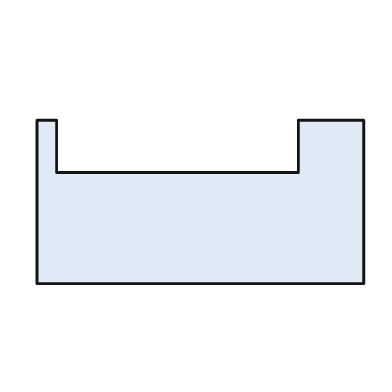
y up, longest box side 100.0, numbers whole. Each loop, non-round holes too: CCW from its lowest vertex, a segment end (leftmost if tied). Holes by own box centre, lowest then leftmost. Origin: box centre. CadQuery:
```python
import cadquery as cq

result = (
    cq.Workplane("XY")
    .moveTo(-50.0, -25.0)
    .lineTo(50.0, -25.0)
    .lineTo(50.0, 25.0)
    .lineTo(30.0, 25.0)
    .lineTo(30.0, 9.0)
    .lineTo(-44.0, 9.0)
    .lineTo(-44.0, 25.0)
    .lineTo(-50.0, 25.0)
    .close()
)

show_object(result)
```